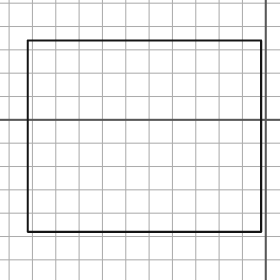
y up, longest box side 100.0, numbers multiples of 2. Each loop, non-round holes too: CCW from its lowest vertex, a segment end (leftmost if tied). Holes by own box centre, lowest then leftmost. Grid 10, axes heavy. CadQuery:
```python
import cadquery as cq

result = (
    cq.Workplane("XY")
    .moveTo(-102.0, -48.0)
    .lineTo(-2.0, -48.0)
    .lineTo(-2.0, 34.0)
    .lineTo(-102.0, 34.0)
    .close()
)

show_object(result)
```